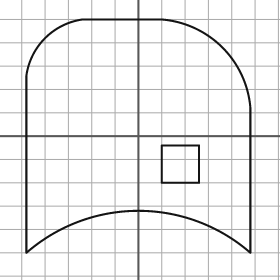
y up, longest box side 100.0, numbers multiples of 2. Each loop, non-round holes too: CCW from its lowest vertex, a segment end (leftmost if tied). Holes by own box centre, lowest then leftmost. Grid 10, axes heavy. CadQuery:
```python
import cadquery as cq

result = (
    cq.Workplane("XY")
    .moveTo(-48.0, -50.0)
    .threePointArc((0.0, -32.0), (48.0, -50.0))
    .lineTo(48.0, 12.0)
    .threePointArc((36.0, 38.0), (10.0, 50.0))
    .lineTo(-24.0, 50.0)
    .threePointArc((-40.0, 42.0), (-48.0, 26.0))
    .close()
    .moveTo(10.0, -20.0)
    .lineTo(26.0, -20.0)
    .lineTo(26.0, -4.0)
    .lineTo(10.0, -4.0)
    .close()
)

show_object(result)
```